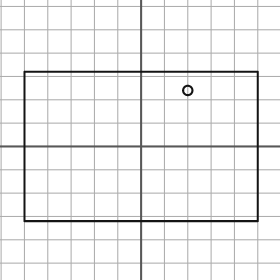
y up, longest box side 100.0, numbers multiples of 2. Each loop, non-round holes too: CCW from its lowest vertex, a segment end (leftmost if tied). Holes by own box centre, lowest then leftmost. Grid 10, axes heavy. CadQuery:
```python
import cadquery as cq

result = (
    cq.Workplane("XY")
    .moveTo(-50.0, -32.0)
    .lineTo(50.0, -32.0)
    .lineTo(50.0, 32.0)
    .lineTo(-50.0, 32.0)
    .close()
    .moveTo(20.0, 24.0)
    .circle(2.0)
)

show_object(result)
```